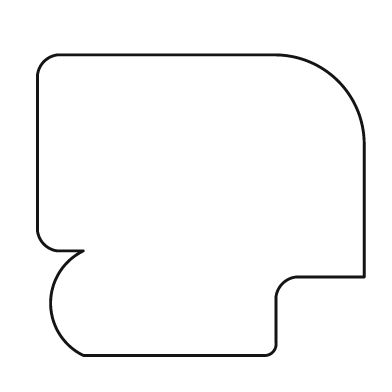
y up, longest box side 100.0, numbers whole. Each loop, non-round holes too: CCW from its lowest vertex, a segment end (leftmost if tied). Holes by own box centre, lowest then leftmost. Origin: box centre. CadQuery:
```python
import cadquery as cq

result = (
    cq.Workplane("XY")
    .moveTo(-36.0, -46.0)
    .lineTo(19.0, -46.0)
    .threePointArc((22.0, -45.0), (23.0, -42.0))
    .lineTo(23.0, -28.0)
    .threePointArc((25.0, -24.0), (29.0, -22.0))
    .lineTo(50.0, -22.0)
    .lineTo(50.0, 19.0)
    .threePointArc((42.0, 38.0), (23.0, 46.0))
    .lineTo(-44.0, 46.0)
    .threePointArc((-48.0, 44.0), (-50.0, 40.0))
    .lineTo(-50.0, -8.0)
    .threePointArc((-48.0, -12.0), (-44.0, -14.0))
    .lineTo(-36.0, -14.0)
    .threePointArc((-46.0, -30.0), (-36.0, -46.0))
    .close()
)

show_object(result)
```